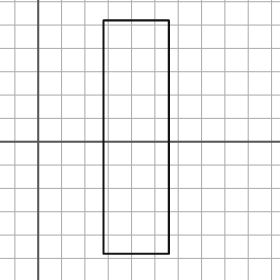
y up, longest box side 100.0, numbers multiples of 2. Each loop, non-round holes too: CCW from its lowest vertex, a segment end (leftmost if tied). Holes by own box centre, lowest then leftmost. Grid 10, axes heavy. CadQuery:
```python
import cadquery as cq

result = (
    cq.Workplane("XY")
    .moveTo(28.0, -48.0)
    .lineTo(56.0, -48.0)
    .lineTo(56.0, 52.0)
    .lineTo(28.0, 52.0)
    .close()
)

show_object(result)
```